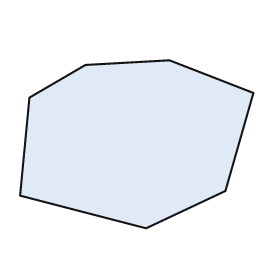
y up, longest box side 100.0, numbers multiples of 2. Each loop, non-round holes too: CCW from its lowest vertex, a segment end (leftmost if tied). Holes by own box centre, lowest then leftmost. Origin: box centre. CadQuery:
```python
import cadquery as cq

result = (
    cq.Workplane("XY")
    .moveTo(4.0, -36.0)
    .lineTo(38.0, -20.0)
    .lineTo(50.0, 22.0)
    .lineTo(14.0, 36.0)
    .lineTo(-22.0, 34.0)
    .lineTo(-46.0, 20.0)
    .lineTo(-50.0, -22.0)
    .close()
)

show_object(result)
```